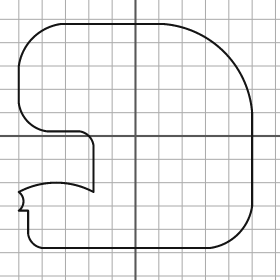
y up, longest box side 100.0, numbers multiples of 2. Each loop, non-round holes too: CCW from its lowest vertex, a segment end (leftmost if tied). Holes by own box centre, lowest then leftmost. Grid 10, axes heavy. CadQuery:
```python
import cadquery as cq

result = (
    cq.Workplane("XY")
    .moveTo(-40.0, -48.0)
    .lineTo(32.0, -48.0)
    .threePointArc((44.0, -42.0), (50.0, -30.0))
    .lineTo(50.0, 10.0)
    .threePointArc((38.0, 36.0), (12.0, 48.0))
    .lineTo(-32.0, 48.0)
    .threePointArc((-44.0, 42.0), (-50.0, 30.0))
    .lineTo(-50.0, 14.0)
    .threePointArc((-46.0, 6.0), (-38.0, 2.0))
    .lineTo(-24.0, 2.0)
    .threePointArc((-20.0, 0.0), (-18.0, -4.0))
    .lineTo(-18.0, -24.0)
    .threePointArc((-34.0, -20.0), (-50.0, -24.0))
    .threePointArc((-48.0, -28.0), (-50.0, -32.0))
    .lineTo(-46.0, -32.0)
    .lineTo(-46.0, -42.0)
    .threePointArc((-44.0, -46.0), (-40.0, -48.0))
    .close()
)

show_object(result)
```